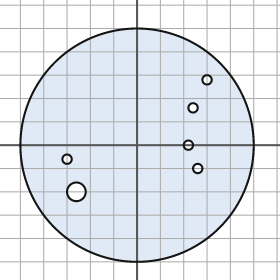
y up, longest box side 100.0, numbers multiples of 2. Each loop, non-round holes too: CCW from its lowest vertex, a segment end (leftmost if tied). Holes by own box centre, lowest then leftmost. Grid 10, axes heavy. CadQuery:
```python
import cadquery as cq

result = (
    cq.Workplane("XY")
    .moveTo(0.0, 0.0)
    .circle(50.0)
    .moveTo(-26.0, -20.0)
    .circle(4.0)
    .moveTo(26.0, -10.0)
    .circle(2.0)
    .moveTo(-30.0, -6.0)
    .circle(2.0)
    .moveTo(22.0, 0.0)
    .circle(2.0)
    .moveTo(24.0, 16.0)
    .circle(2.0)
    .moveTo(30.0, 28.0)
    .circle(2.0)
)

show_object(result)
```